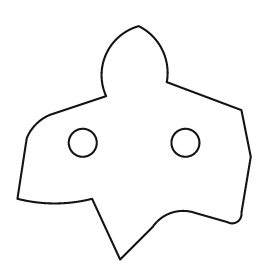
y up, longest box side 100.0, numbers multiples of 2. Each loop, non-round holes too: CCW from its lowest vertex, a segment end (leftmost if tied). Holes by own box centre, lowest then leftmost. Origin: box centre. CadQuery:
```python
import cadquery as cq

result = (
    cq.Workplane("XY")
    .moveTo(-6.0, -50.0)
    .lineTo(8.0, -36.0)
    .threePointArc((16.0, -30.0), (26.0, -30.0))
    .lineTo(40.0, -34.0)
    .threePointArc((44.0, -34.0), (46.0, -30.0))
    .lineTo(50.0, -6.0)
    .lineTo(46.0, 14.0)
    .lineTo(14.0, 26.0)
    .threePointArc((12.0, 40.0), (2.0, 50.0))
    .threePointArc((-12.0, 38.0), (-12.0, 20.0))
    .lineTo(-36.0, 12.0)
    .threePointArc((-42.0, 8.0), (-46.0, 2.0))
    .lineTo(-50.0, -24.0)
    .threePointArc((-34.0, -26.0), (-18.0, -24.0))
    .close()
    .moveTo(-22.0, 0.0)
    .circle(6.0)
    .moveTo(22.0, 0.0)
    .circle(6.0)
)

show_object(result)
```